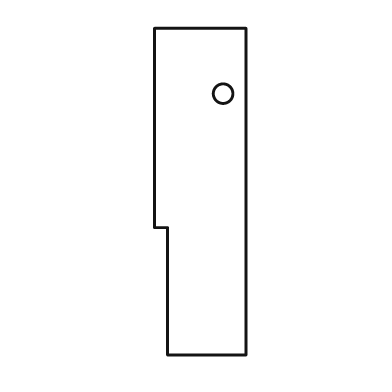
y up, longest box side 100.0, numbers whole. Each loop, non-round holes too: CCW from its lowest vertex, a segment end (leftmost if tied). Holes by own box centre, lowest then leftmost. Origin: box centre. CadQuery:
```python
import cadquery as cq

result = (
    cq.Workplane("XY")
    .moveTo(-10.0, -50.0)
    .lineTo(14.0, -50.0)
    .lineTo(14.0, 50.0)
    .lineTo(-14.0, 50.0)
    .lineTo(-14.0, -11.0)
    .lineTo(-10.0, -11.0)
    .close()
    .moveTo(7.0, 30.0)
    .circle(3.0)
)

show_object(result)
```